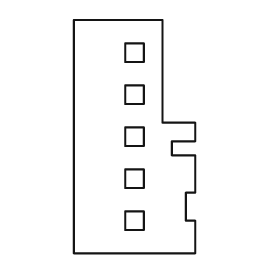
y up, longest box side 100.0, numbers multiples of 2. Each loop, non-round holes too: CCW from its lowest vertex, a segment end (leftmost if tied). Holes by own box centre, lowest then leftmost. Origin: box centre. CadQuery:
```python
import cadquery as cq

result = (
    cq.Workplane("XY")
    .moveTo(-26.0, -50.0)
    .lineTo(26.0, -50.0)
    .lineTo(26.0, -36.0)
    .lineTo(22.0, -36.0)
    .lineTo(22.0, -24.0)
    .lineTo(26.0, -24.0)
    .lineTo(26.0, -8.0)
    .lineTo(16.0, -8.0)
    .lineTo(16.0, -2.0)
    .lineTo(26.0, -2.0)
    .lineTo(26.0, 6.0)
    .lineTo(12.0, 6.0)
    .lineTo(12.0, 50.0)
    .lineTo(-26.0, 50.0)
    .close()
    .moveTo(-4.0, -40.0)
    .lineTo(4.0, -40.0)
    .lineTo(4.0, -32.0)
    .lineTo(-4.0, -32.0)
    .close()
    .moveTo(-4.0, -22.0)
    .lineTo(4.0, -22.0)
    .lineTo(4.0, -14.0)
    .lineTo(-4.0, -14.0)
    .close()
    .moveTo(-4.0, -4.0)
    .lineTo(4.0, -4.0)
    .lineTo(4.0, 4.0)
    .lineTo(-4.0, 4.0)
    .close()
    .moveTo(-4.0, 14.0)
    .lineTo(4.0, 14.0)
    .lineTo(4.0, 22.0)
    .lineTo(-4.0, 22.0)
    .close()
    .moveTo(-4.0, 32.0)
    .lineTo(4.0, 32.0)
    .lineTo(4.0, 40.0)
    .lineTo(-4.0, 40.0)
    .close()
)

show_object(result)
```